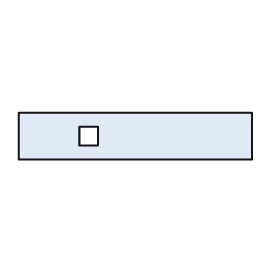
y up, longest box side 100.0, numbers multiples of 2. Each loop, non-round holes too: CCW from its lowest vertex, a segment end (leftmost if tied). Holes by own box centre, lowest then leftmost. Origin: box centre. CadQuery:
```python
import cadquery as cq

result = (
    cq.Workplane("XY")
    .moveTo(-50.0, -10.0)
    .lineTo(50.0, -10.0)
    .lineTo(50.0, 10.0)
    .lineTo(-50.0, 10.0)
    .close()
    .moveTo(-24.0, -4.0)
    .lineTo(-16.0, -4.0)
    .lineTo(-16.0, 4.0)
    .lineTo(-24.0, 4.0)
    .close()
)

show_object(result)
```